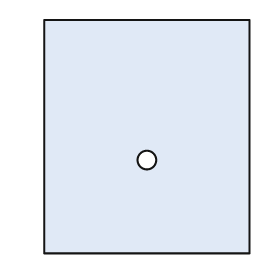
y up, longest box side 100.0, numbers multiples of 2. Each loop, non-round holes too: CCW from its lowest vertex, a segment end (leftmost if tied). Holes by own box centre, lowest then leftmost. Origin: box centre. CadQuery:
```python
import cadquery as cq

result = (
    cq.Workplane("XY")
    .moveTo(-44.0, -50.0)
    .lineTo(44.0, -50.0)
    .lineTo(44.0, 50.0)
    .lineTo(-44.0, 50.0)
    .close()
    .moveTo(0.0, -10.0)
    .circle(4.0)
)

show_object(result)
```